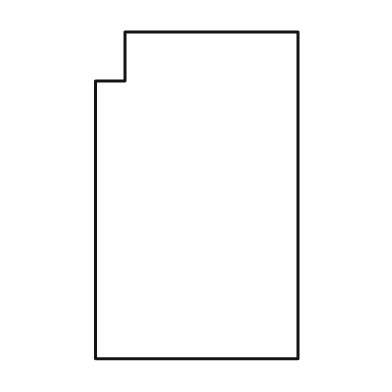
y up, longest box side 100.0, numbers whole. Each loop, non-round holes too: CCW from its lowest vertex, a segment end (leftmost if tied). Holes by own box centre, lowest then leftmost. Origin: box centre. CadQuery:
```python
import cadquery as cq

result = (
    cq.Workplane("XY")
    .moveTo(-31.0, -50.0)
    .lineTo(31.0, -50.0)
    .lineTo(31.0, 50.0)
    .lineTo(-22.0, 50.0)
    .lineTo(-22.0, 35.0)
    .lineTo(-31.0, 35.0)
    .close()
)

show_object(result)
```